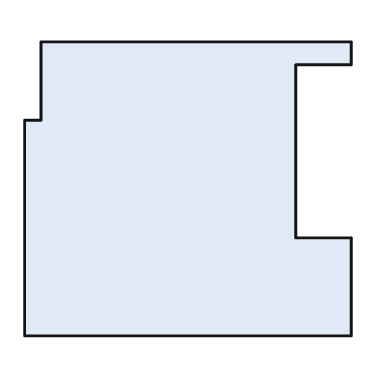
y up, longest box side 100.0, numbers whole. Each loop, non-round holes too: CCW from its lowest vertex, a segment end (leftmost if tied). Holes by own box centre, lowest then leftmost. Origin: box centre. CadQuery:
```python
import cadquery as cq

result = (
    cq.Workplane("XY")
    .moveTo(-50.0, -45.0)
    .lineTo(50.0, -45.0)
    .lineTo(50.0, -15.0)
    .lineTo(33.0, -15.0)
    .lineTo(33.0, 38.0)
    .lineTo(50.0, 38.0)
    .lineTo(50.0, 45.0)
    .lineTo(-45.0, 45.0)
    .lineTo(-45.0, 21.0)
    .lineTo(-50.0, 21.0)
    .close()
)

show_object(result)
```